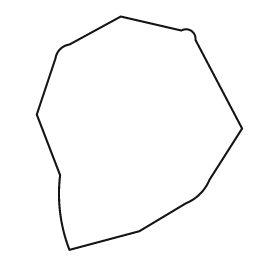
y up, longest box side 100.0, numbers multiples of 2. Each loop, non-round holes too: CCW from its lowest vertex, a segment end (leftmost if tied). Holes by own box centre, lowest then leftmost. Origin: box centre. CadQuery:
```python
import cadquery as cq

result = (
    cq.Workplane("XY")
    .moveTo(-30.0, -50.0)
    .lineTo(0.0, -42.0)
    .lineTo(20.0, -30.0)
    .threePointArc((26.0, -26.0), (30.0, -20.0))
    .lineTo(44.0, 2.0)
    .lineTo(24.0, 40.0)
    .threePointArc((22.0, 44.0), (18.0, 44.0))
    .lineTo(-8.0, 50.0)
    .lineTo(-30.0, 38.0)
    .threePointArc((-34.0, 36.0), (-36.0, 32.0))
    .lineTo(-44.0, 8.0)
    .lineTo(-34.0, -18.0)
    .threePointArc((-34.0, -34.0), (-30.0, -50.0))
    .close()
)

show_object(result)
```